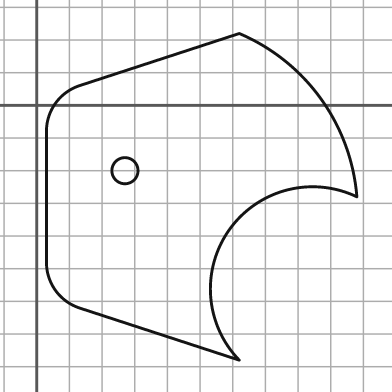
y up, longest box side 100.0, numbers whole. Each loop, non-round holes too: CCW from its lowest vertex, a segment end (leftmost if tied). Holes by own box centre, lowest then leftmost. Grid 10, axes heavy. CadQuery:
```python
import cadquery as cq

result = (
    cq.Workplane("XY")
    .moveTo(62.0, -78.0)
    .threePointArc((59.0, -38.0), (98.0, -28.0))
    .threePointArc((87.0, 2.0), (62.0, 22.0))
    .lineTo(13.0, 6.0)
    .threePointArc((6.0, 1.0), (3.0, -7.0))
    .lineTo(3.0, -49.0)
    .threePointArc((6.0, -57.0), (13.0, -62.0))
    .close()
    .moveTo(27.0, -20.0)
    .circle(4.0)
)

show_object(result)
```